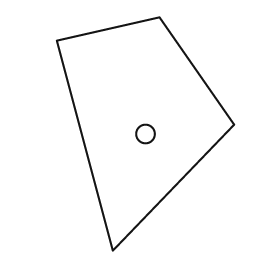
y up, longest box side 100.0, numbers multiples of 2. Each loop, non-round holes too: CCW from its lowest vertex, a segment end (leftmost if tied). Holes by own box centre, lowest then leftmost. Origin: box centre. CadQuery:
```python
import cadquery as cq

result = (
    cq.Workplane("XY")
    .moveTo(-14.0, -50.0)
    .lineTo(38.0, 4.0)
    .lineTo(6.0, 50.0)
    .lineTo(-38.0, 40.0)
    .close()
    .moveTo(0.0, 0.0)
    .circle(4.0)
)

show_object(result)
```